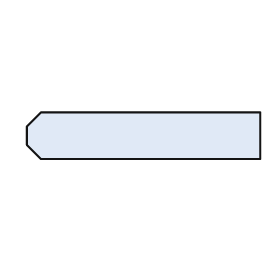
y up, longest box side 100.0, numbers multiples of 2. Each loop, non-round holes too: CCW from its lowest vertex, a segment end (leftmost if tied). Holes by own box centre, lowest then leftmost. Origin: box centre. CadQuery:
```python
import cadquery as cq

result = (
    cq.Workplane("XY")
    .moveTo(-44.0, -10.0)
    .lineTo(50.0, -10.0)
    .lineTo(50.0, 10.0)
    .lineTo(-44.0, 10.0)
    .lineTo(-50.0, 4.0)
    .lineTo(-50.0, -4.0)
    .close()
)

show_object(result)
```